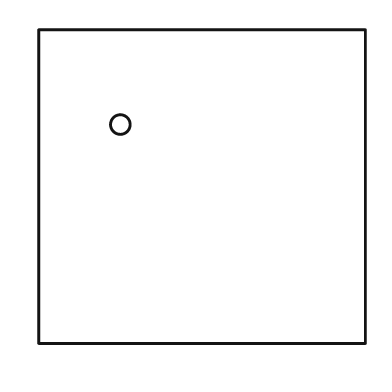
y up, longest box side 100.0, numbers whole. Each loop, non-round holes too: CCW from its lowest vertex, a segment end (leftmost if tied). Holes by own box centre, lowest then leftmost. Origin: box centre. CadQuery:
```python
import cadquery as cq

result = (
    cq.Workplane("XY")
    .moveTo(-50.0, -48.0)
    .lineTo(50.0, -48.0)
    .lineTo(50.0, 48.0)
    .lineTo(-50.0, 48.0)
    .close()
    .moveTo(-25.0, 19.0)
    .circle(3.0)
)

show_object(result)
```